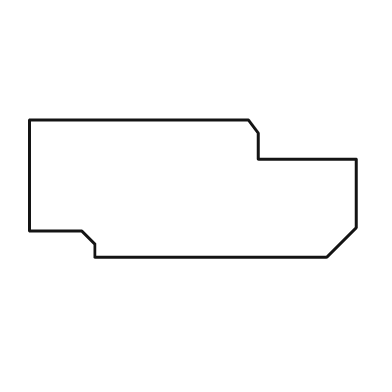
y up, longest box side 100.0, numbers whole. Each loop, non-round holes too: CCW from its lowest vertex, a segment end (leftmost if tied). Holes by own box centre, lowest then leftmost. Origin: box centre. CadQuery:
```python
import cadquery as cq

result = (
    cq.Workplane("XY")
    .moveTo(-30.0, -21.0)
    .lineTo(41.0, -21.0)
    .lineTo(50.0, -12.0)
    .lineTo(50.0, 9.0)
    .lineTo(20.0, 9.0)
    .lineTo(20.0, 17.0)
    .lineTo(17.0, 21.0)
    .lineTo(-50.0, 21.0)
    .lineTo(-50.0, -13.0)
    .lineTo(-34.0, -13.0)
    .lineTo(-30.0, -17.0)
    .close()
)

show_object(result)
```